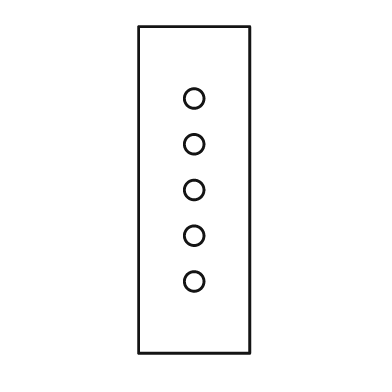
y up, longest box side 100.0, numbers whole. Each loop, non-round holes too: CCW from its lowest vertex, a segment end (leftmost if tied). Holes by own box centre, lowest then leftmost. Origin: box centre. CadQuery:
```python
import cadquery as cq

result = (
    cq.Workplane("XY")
    .moveTo(-17.0, -50.0)
    .lineTo(17.0, -50.0)
    .lineTo(17.0, 50.0)
    .lineTo(-17.0, 50.0)
    .close()
    .moveTo(0.0, -28.0)
    .circle(3.0)
    .moveTo(0.0, -14.0)
    .circle(3.0)
    .moveTo(0.0, 0.0)
    .circle(3.0)
    .moveTo(0.0, 14.0)
    .circle(3.0)
    .moveTo(0.0, 28.0)
    .circle(3.0)
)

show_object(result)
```